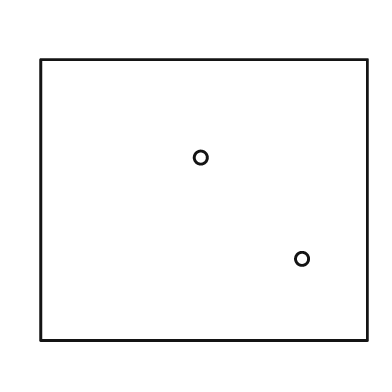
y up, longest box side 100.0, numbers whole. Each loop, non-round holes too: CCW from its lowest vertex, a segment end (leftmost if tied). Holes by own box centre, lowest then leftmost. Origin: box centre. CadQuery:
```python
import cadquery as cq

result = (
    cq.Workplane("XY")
    .moveTo(-50.0, -43.0)
    .lineTo(50.0, -43.0)
    .lineTo(50.0, 43.0)
    .lineTo(-50.0, 43.0)
    .close()
    .moveTo(30.0, -18.0)
    .circle(2.0)
    .moveTo(-1.0, 13.0)
    .circle(2.0)
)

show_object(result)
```